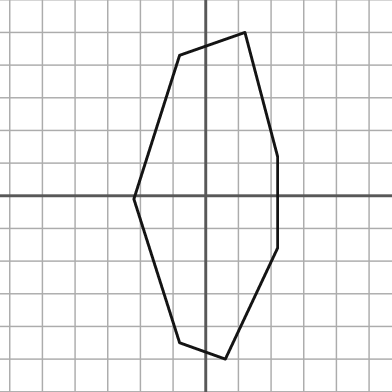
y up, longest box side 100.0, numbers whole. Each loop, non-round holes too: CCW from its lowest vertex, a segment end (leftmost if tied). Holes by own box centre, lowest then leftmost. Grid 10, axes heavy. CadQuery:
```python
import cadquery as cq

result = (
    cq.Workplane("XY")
    .moveTo(6.0, -50.0)
    .lineTo(22.0, -16.0)
    .lineTo(22.0, 12.0)
    .lineTo(12.0, 50.0)
    .lineTo(-8.0, 43.0)
    .lineTo(-22.0, -1.0)
    .lineTo(-8.0, -45.0)
    .close()
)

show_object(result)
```